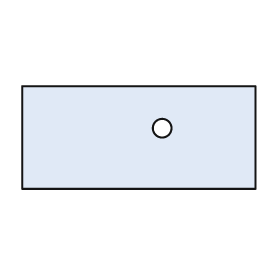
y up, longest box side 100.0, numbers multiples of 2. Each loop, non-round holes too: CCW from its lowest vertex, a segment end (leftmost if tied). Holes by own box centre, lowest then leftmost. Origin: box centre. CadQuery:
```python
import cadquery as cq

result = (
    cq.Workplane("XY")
    .moveTo(-50.0, -22.0)
    .lineTo(50.0, -22.0)
    .lineTo(50.0, 22.0)
    .lineTo(-50.0, 22.0)
    .close()
    .moveTo(10.0, 4.0)
    .circle(4.0)
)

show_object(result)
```